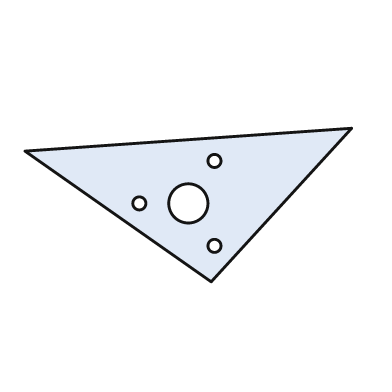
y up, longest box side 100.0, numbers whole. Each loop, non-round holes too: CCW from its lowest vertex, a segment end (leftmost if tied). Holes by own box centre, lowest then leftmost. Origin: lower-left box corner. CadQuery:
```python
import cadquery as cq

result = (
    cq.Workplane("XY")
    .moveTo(57.0, 0.0)
    .lineTo(100.0, 47.0)
    .lineTo(0.0, 40.0)
    .close()
    .moveTo(58.0, 11.0)
    .circle(2.0)
    .moveTo(35.0, 24.0)
    .circle(2.0)
    .moveTo(50.0, 24.0)
    .circle(6.0)
    .moveTo(58.0, 37.0)
    .circle(2.0)
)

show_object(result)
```